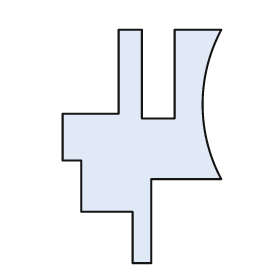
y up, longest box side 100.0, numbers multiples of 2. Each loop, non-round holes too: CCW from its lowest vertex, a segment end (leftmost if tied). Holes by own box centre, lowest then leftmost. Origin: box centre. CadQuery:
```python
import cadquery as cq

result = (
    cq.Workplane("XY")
    .moveTo(-4.0, -50.0)
    .lineTo(4.0, -50.0)
    .lineTo(4.0, -14.0)
    .lineTo(34.0, -14.0)
    .threePointArc((26.0, 18.0), (34.0, 50.0))
    .lineTo(14.0, 50.0)
    .lineTo(14.0, 12.0)
    .lineTo(0.0, 12.0)
    .lineTo(0.0, 50.0)
    .lineTo(-10.0, 50.0)
    .lineTo(-10.0, 14.0)
    .lineTo(-34.0, 14.0)
    .lineTo(-34.0, -6.0)
    .lineTo(-26.0, -6.0)
    .lineTo(-26.0, -28.0)
    .lineTo(-4.0, -28.0)
    .close()
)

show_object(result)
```